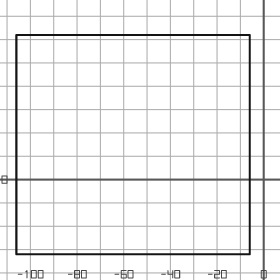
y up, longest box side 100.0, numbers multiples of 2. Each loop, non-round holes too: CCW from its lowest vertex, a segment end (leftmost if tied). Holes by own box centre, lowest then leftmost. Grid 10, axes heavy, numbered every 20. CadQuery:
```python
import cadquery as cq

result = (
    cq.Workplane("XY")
    .moveTo(-106.0, -32.0)
    .lineTo(-6.0, -32.0)
    .lineTo(-6.0, 62.0)
    .lineTo(-106.0, 62.0)
    .close()
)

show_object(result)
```